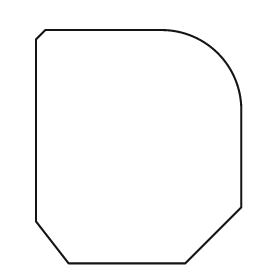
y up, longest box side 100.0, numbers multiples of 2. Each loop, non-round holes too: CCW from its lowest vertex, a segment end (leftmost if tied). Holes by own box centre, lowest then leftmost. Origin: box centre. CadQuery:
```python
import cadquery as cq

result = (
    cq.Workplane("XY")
    .moveTo(-30.0, -50.0)
    .lineTo(20.0, -50.0)
    .lineTo(44.0, -26.0)
    .lineTo(44.0, 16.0)
    .threePointArc((34.0, 40.0), (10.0, 50.0))
    .lineTo(-40.0, 50.0)
    .lineTo(-44.0, 46.0)
    .lineTo(-44.0, -32.0)
    .close()
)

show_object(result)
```